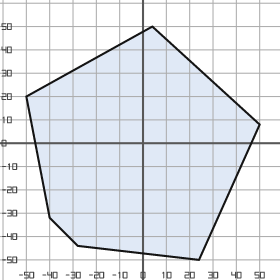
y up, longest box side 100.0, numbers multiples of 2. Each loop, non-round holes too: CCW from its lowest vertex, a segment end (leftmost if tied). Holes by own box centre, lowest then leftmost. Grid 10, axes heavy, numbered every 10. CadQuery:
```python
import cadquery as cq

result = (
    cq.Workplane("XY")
    .moveTo(24.0, -50.0)
    .lineTo(50.0, 8.0)
    .lineTo(4.0, 50.0)
    .lineTo(-50.0, 20.0)
    .lineTo(-40.0, -32.0)
    .lineTo(-28.0, -44.0)
    .close()
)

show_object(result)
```